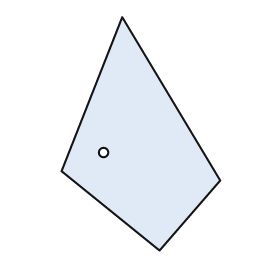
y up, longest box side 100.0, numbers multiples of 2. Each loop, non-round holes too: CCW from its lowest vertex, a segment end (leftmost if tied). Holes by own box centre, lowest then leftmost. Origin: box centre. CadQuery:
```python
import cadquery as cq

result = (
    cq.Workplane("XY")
    .moveTo(8.0, -50.0)
    .lineTo(34.0, -20.0)
    .lineTo(-8.0, 50.0)
    .lineTo(-34.0, -16.0)
    .close()
    .moveTo(-16.0, -8.0)
    .circle(2.0)
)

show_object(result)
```